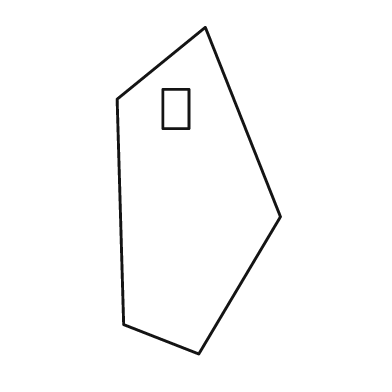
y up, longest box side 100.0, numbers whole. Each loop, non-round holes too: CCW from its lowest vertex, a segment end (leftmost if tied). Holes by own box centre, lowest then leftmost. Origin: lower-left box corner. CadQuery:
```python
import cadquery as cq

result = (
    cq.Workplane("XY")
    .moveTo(25.0, 0.0)
    .lineTo(50.0, 42.0)
    .lineTo(27.0, 100.0)
    .lineTo(0.0, 78.0)
    .lineTo(2.0, 9.0)
    .close()
    .moveTo(14.0, 69.0)
    .lineTo(22.0, 69.0)
    .lineTo(22.0, 81.0)
    .lineTo(14.0, 81.0)
    .close()
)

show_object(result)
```